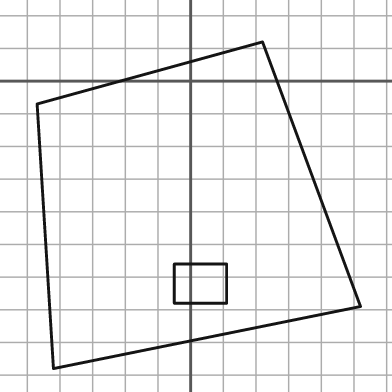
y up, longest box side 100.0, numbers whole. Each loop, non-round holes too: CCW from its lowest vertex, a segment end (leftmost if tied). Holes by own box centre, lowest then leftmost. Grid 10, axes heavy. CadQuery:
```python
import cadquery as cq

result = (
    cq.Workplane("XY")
    .moveTo(-42.0, -88.0)
    .lineTo(52.0, -69.0)
    .lineTo(22.0, 12.0)
    .lineTo(-47.0, -7.0)
    .close()
    .moveTo(-5.0, -68.0)
    .lineTo(11.0, -68.0)
    .lineTo(11.0, -56.0)
    .lineTo(-5.0, -56.0)
    .close()
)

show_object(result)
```